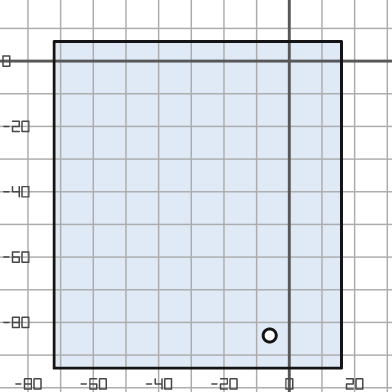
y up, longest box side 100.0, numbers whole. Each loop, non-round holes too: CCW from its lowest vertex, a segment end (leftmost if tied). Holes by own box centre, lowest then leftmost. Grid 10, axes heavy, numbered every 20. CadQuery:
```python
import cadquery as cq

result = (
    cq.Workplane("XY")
    .moveTo(-72.0, -94.0)
    .lineTo(16.0, -94.0)
    .lineTo(16.0, 6.0)
    .lineTo(-72.0, 6.0)
    .close()
    .moveTo(-6.0, -84.0)
    .circle(2.0)
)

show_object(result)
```